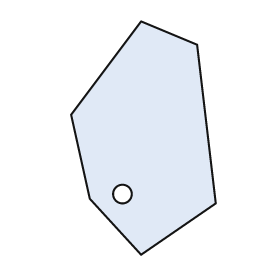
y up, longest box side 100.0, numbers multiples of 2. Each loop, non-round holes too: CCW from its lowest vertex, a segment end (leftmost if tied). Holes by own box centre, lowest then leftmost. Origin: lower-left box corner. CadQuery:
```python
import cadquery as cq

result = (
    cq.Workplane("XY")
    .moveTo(30.0, 0.0)
    .lineTo(62.0, 22.0)
    .lineTo(54.0, 90.0)
    .lineTo(30.0, 100.0)
    .lineTo(0.0, 60.0)
    .lineTo(8.0, 24.0)
    .close()
    .moveTo(22.0, 26.0)
    .circle(4.0)
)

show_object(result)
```